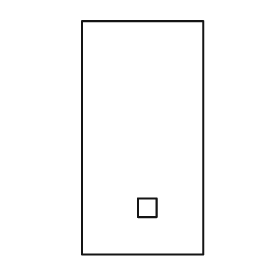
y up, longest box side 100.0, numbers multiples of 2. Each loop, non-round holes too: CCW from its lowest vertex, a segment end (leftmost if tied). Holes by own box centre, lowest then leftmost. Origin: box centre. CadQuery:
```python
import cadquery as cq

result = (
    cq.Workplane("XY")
    .moveTo(-26.0, -50.0)
    .lineTo(26.0, -50.0)
    .lineTo(26.0, 50.0)
    .lineTo(-26.0, 50.0)
    .close()
    .moveTo(-2.0, -34.0)
    .lineTo(6.0, -34.0)
    .lineTo(6.0, -26.0)
    .lineTo(-2.0, -26.0)
    .close()
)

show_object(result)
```